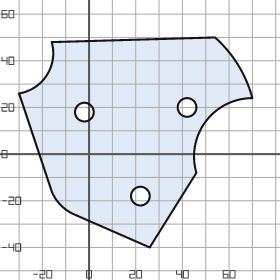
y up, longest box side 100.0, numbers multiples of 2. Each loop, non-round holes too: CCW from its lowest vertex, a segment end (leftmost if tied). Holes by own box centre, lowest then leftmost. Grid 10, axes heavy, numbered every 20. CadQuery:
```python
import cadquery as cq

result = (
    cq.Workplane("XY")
    .moveTo(26.0, -40.0)
    .lineTo(46.0, -8.0)
    .threePointArc((50.0, 14.0), (70.0, 24.0))
    .threePointArc((64.0, 38.0), (54.0, 50.0))
    .lineTo(-16.0, 48.0)
    .threePointArc((-18.0, 34.0), (-30.0, 26.0))
    .lineTo(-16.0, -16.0)
    .threePointArc((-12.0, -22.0), (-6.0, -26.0))
    .close()
    .moveTo(22.0, -18.0)
    .circle(4.0)
    .moveTo(-2.0, 18.0)
    .circle(4.0)
    .moveTo(42.0, 20.0)
    .circle(4.0)
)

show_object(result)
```